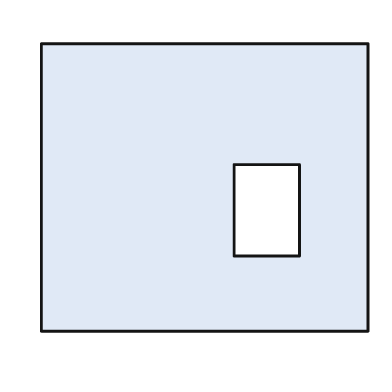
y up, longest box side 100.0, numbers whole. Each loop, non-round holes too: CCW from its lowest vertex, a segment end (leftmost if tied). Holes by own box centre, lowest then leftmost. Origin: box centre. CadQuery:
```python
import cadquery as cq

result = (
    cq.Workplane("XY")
    .moveTo(-50.0, -44.0)
    .lineTo(50.0, -44.0)
    .lineTo(50.0, 44.0)
    .lineTo(-50.0, 44.0)
    .close()
    .moveTo(9.0, -21.0)
    .lineTo(29.0, -21.0)
    .lineTo(29.0, 7.0)
    .lineTo(9.0, 7.0)
    .close()
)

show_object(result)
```